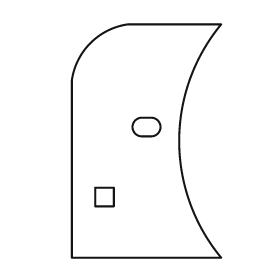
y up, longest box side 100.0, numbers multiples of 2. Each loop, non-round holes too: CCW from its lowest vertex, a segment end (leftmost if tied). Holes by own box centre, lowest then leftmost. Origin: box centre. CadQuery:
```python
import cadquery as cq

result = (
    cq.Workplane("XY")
    .moveTo(-32.0, -50.0)
    .lineTo(32.0, -50.0)
    .threePointArc((14.0, 0.0), (32.0, 50.0))
    .lineTo(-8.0, 50.0)
    .threePointArc((-24.0, 42.0), (-32.0, 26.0))
    .close()
    .moveTo(-22.0, -28.0)
    .lineTo(-14.0, -28.0)
    .lineTo(-14.0, -20.0)
    .lineTo(-22.0, -20.0)
    .close()
    .moveTo(-2.0, 2.0)
    .lineTo(2.0, 2.0)
    .threePointArc((6.0, 6.0), (2.0, 10.0))
    .lineTo(-2.0, 10.0)
    .threePointArc((-6.0, 6.0), (-2.0, 2.0))
    .close()
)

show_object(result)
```